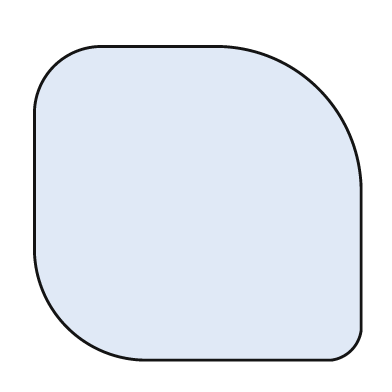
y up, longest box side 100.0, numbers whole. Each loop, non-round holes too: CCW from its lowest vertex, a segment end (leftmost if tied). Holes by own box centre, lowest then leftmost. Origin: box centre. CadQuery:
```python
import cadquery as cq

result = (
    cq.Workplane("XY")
    .moveTo(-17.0, -48.0)
    .lineTo(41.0, -48.0)
    .threePointArc((47.0, -45.0), (50.0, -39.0))
    .lineTo(50.0, 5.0)
    .threePointArc((37.0, 35.0), (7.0, 48.0))
    .lineTo(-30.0, 48.0)
    .threePointArc((-44.0, 42.0), (-50.0, 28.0))
    .lineTo(-50.0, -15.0)
    .threePointArc((-40.0, -38.0), (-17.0, -48.0))
    .close()
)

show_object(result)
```